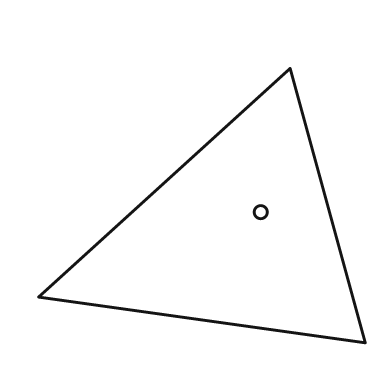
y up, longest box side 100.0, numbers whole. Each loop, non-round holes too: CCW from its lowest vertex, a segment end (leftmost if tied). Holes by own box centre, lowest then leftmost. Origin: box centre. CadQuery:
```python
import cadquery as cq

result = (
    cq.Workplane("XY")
    .moveTo(50.0, -42.0)
    .lineTo(27.0, 42.0)
    .lineTo(-50.0, -28.0)
    .close()
    .moveTo(18.0, -2.0)
    .circle(2.0)
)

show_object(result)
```